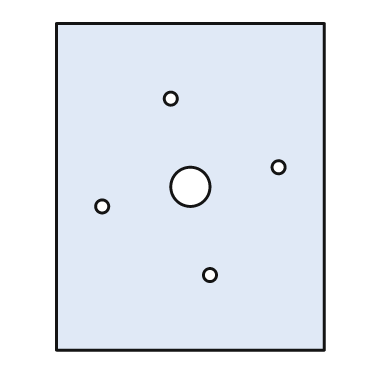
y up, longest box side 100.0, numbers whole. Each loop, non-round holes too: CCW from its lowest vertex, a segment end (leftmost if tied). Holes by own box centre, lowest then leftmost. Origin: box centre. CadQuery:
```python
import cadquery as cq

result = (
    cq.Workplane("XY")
    .moveTo(-41.0, -50.0)
    .lineTo(41.0, -50.0)
    .lineTo(41.0, 50.0)
    .lineTo(-41.0, 50.0)
    .close()
    .moveTo(6.0, -27.0)
    .circle(2.0)
    .moveTo(-27.0, -6.0)
    .circle(2.0)
    .moveTo(0.0, 0.0)
    .circle(6.0)
    .moveTo(27.0, 6.0)
    .circle(2.0)
    .moveTo(-6.0, 27.0)
    .circle(2.0)
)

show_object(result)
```